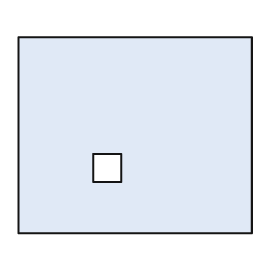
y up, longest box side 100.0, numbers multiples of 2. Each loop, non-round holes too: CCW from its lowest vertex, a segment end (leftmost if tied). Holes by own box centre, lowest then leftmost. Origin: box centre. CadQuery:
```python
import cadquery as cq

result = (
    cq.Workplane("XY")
    .moveTo(-50.0, -42.0)
    .lineTo(50.0, -42.0)
    .lineTo(50.0, 42.0)
    .lineTo(-50.0, 42.0)
    .close()
    .moveTo(-18.0, -20.0)
    .lineTo(-6.0, -20.0)
    .lineTo(-6.0, -8.0)
    .lineTo(-18.0, -8.0)
    .close()
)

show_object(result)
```